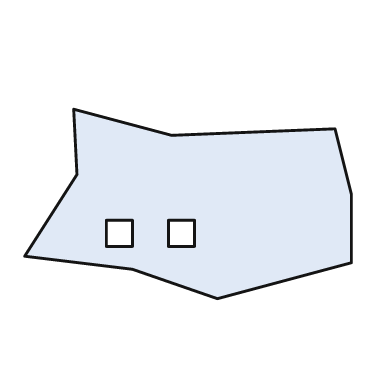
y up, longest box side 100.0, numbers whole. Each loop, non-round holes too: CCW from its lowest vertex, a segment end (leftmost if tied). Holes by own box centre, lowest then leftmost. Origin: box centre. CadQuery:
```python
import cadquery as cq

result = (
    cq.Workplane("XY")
    .moveTo(9.0, -29.0)
    .lineTo(50.0, -18.0)
    .lineTo(50.0, 3.0)
    .lineTo(45.0, 23.0)
    .lineTo(-5.0, 21.0)
    .lineTo(-35.0, 29.0)
    .lineTo(-34.0, 9.0)
    .lineTo(-50.0, -16.0)
    .lineTo(-17.0, -20.0)
    .close()
    .moveTo(-25.0, -13.0)
    .lineTo(-17.0, -13.0)
    .lineTo(-17.0, -5.0)
    .lineTo(-25.0, -5.0)
    .close()
    .moveTo(-6.0, -13.0)
    .lineTo(2.0, -13.0)
    .lineTo(2.0, -5.0)
    .lineTo(-6.0, -5.0)
    .close()
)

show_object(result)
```